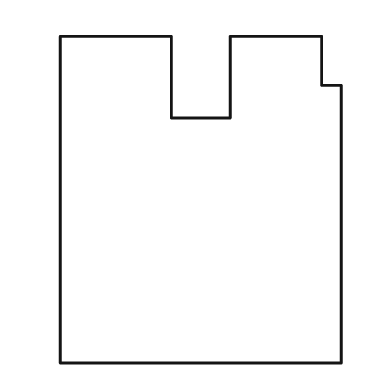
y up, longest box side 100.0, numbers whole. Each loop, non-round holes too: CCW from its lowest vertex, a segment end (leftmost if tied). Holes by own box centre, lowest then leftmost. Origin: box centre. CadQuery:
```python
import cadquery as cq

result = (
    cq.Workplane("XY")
    .moveTo(-43.0, -50.0)
    .lineTo(43.0, -50.0)
    .lineTo(43.0, 35.0)
    .lineTo(37.0, 35.0)
    .lineTo(37.0, 50.0)
    .lineTo(9.0, 50.0)
    .lineTo(9.0, 25.0)
    .lineTo(-9.0, 25.0)
    .lineTo(-9.0, 50.0)
    .lineTo(-43.0, 50.0)
    .close()
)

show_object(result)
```